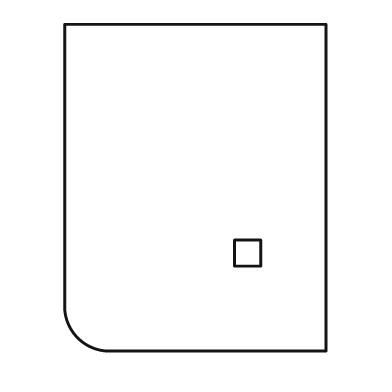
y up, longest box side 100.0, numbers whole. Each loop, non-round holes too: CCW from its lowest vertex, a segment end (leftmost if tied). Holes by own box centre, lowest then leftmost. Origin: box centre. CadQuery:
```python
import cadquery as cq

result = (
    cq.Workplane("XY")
    .moveTo(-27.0, -50.0)
    .lineTo(40.0, -50.0)
    .lineTo(40.0, 50.0)
    .lineTo(-40.0, 50.0)
    .lineTo(-40.0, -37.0)
    .threePointArc((-36.0, -46.0), (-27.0, -50.0))
    .close()
    .moveTo(12.0, -24.0)
    .lineTo(20.0, -24.0)
    .lineTo(20.0, -16.0)
    .lineTo(12.0, -16.0)
    .close()
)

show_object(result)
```